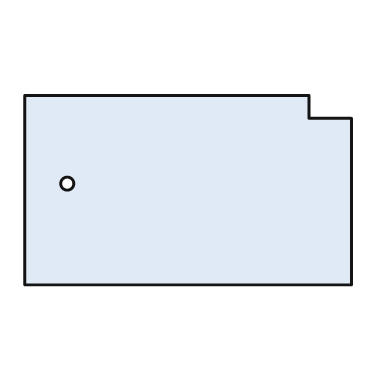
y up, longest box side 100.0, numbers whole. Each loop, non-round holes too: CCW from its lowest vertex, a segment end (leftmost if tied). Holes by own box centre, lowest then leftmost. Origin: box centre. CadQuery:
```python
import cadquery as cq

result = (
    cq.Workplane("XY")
    .moveTo(-50.0, -29.0)
    .lineTo(50.0, -29.0)
    .lineTo(50.0, 22.0)
    .lineTo(37.0, 22.0)
    .lineTo(37.0, 29.0)
    .lineTo(-50.0, 29.0)
    .close()
    .moveTo(-37.0, 2.0)
    .circle(2.0)
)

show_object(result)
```